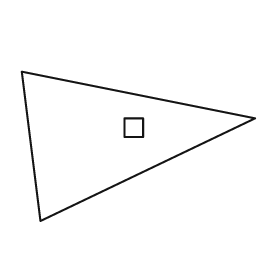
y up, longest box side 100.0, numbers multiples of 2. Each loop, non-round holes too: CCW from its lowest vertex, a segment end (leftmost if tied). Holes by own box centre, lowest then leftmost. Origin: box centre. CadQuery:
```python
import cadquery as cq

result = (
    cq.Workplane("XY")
    .moveTo(-42.0, -32.0)
    .lineTo(50.0, 12.0)
    .lineTo(-50.0, 32.0)
    .close()
    .moveTo(-6.0, 4.0)
    .lineTo(2.0, 4.0)
    .lineTo(2.0, 12.0)
    .lineTo(-6.0, 12.0)
    .close()
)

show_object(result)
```